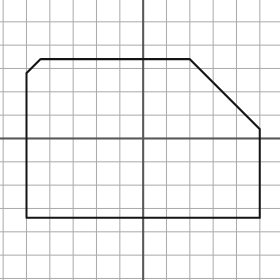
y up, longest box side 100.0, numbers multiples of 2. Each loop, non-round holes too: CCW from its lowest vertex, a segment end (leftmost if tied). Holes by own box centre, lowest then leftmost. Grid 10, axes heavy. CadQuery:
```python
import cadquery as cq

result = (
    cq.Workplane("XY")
    .moveTo(-50.0, -34.0)
    .lineTo(50.0, -34.0)
    .lineTo(50.0, 4.0)
    .lineTo(20.0, 34.0)
    .lineTo(-44.0, 34.0)
    .lineTo(-50.0, 28.0)
    .close()
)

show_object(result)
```